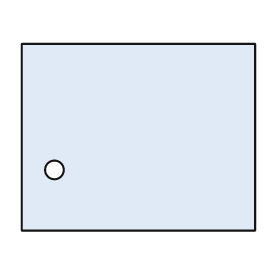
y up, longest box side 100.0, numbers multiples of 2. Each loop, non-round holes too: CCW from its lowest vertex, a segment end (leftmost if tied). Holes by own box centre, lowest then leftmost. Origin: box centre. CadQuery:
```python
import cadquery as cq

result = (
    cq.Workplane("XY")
    .moveTo(-50.0, -40.0)
    .lineTo(50.0, -40.0)
    .lineTo(50.0, 40.0)
    .lineTo(-50.0, 40.0)
    .close()
    .moveTo(-36.0, -14.0)
    .circle(4.0)
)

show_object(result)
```